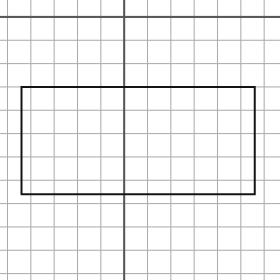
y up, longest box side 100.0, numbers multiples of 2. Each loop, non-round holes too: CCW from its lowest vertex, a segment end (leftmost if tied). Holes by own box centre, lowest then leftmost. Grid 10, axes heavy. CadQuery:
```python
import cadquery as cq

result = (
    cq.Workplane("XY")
    .moveTo(-44.0, -76.0)
    .lineTo(56.0, -76.0)
    .lineTo(56.0, -30.0)
    .lineTo(-44.0, -30.0)
    .close()
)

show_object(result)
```